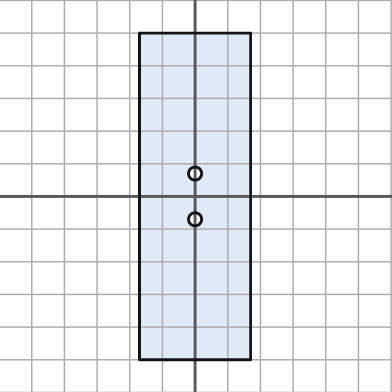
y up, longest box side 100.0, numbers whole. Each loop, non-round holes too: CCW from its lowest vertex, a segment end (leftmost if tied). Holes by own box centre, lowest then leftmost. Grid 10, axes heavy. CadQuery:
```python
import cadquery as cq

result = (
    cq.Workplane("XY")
    .moveTo(-17.0, -50.0)
    .lineTo(17.0, -50.0)
    .lineTo(17.0, 50.0)
    .lineTo(-17.0, 50.0)
    .close()
    .moveTo(0.0, -7.0)
    .circle(2.0)
    .moveTo(0.0, 7.0)
    .circle(2.0)
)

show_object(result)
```